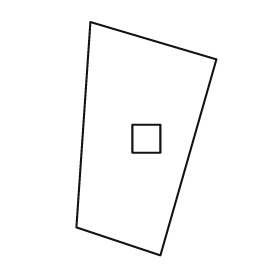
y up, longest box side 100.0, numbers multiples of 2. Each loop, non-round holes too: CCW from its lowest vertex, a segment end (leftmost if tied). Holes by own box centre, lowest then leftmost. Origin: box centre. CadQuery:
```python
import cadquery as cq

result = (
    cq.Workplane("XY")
    .moveTo(6.0, -50.0)
    .lineTo(30.0, 34.0)
    .lineTo(-24.0, 50.0)
    .lineTo(-30.0, -38.0)
    .close()
    .moveTo(-6.0, -6.0)
    .lineTo(6.0, -6.0)
    .lineTo(6.0, 6.0)
    .lineTo(-6.0, 6.0)
    .close()
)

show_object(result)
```